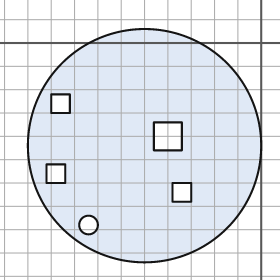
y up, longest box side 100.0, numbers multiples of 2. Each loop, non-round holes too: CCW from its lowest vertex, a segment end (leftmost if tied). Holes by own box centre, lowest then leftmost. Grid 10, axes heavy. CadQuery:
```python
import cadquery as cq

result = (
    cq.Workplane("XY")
    .moveTo(-50.0, -44.0)
    .circle(50.0)
    .moveTo(-74.0, -78.0)
    .circle(4.0)
    .moveTo(-38.0, -68.0)
    .lineTo(-30.0, -68.0)
    .lineTo(-30.0, -60.0)
    .lineTo(-38.0, -60.0)
    .close()
    .moveTo(-92.0, -60.0)
    .lineTo(-84.0, -60.0)
    .lineTo(-84.0, -52.0)
    .lineTo(-92.0, -52.0)
    .close()
    .moveTo(-46.0, -46.0)
    .lineTo(-34.0, -46.0)
    .lineTo(-34.0, -34.0)
    .lineTo(-46.0, -34.0)
    .close()
    .moveTo(-90.0, -30.0)
    .lineTo(-82.0, -30.0)
    .lineTo(-82.0, -22.0)
    .lineTo(-90.0, -22.0)
    .close()
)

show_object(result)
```